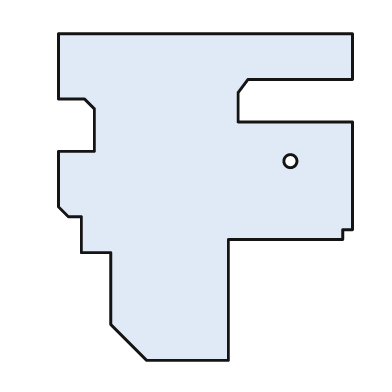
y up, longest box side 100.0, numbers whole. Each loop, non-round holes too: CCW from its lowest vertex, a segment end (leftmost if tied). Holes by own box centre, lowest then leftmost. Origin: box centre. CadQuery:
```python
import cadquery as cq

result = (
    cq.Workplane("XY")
    .moveTo(-18.0, -50.0)
    .lineTo(7.0, -50.0)
    .lineTo(7.0, -13.0)
    .lineTo(42.0, -13.0)
    .lineTo(42.0, -10.0)
    .lineTo(45.0, -10.0)
    .lineTo(45.0, 23.0)
    .lineTo(10.0, 23.0)
    .lineTo(10.0, 32.0)
    .lineTo(13.0, 36.0)
    .lineTo(45.0, 36.0)
    .lineTo(45.0, 50.0)
    .lineTo(-45.0, 50.0)
    .lineTo(-45.0, 30.0)
    .lineTo(-37.0, 30.0)
    .lineTo(-34.0, 27.0)
    .lineTo(-34.0, 14.0)
    .lineTo(-45.0, 14.0)
    .lineTo(-45.0, -3.0)
    .lineTo(-42.0, -6.0)
    .lineTo(-38.0, -6.0)
    .lineTo(-38.0, -17.0)
    .lineTo(-29.0, -17.0)
    .lineTo(-29.0, -39.0)
    .close()
    .moveTo(26.0, 11.0)
    .circle(2.0)
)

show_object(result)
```